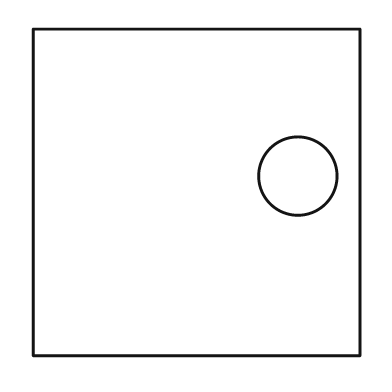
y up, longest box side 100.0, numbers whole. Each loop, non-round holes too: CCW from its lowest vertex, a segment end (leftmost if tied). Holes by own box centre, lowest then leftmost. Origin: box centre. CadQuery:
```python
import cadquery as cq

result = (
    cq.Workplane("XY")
    .moveTo(-50.0, -50.0)
    .lineTo(50.0, -50.0)
    .lineTo(50.0, 50.0)
    .lineTo(-50.0, 50.0)
    .close()
    .moveTo(31.0, 5.0)
    .circle(12.0)
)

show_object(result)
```